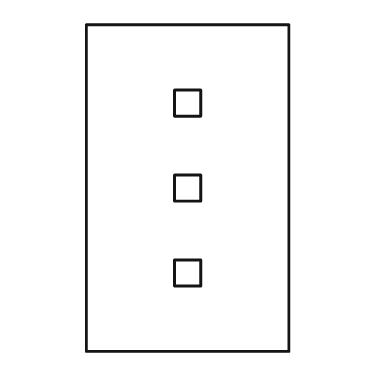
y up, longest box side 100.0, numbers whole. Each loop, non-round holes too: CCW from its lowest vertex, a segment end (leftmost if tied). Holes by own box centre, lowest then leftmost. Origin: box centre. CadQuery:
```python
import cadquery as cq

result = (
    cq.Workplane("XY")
    .moveTo(-31.0, -50.0)
    .lineTo(31.0, -50.0)
    .lineTo(31.0, 50.0)
    .lineTo(-31.0, 50.0)
    .close()
    .moveTo(-4.0, -30.0)
    .lineTo(4.0, -30.0)
    .lineTo(4.0, -22.0)
    .lineTo(-4.0, -22.0)
    .close()
    .moveTo(-4.0, -4.0)
    .lineTo(4.0, -4.0)
    .lineTo(4.0, 4.0)
    .lineTo(-4.0, 4.0)
    .close()
    .moveTo(-4.0, 22.0)
    .lineTo(4.0, 22.0)
    .lineTo(4.0, 30.0)
    .lineTo(-4.0, 30.0)
    .close()
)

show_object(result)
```